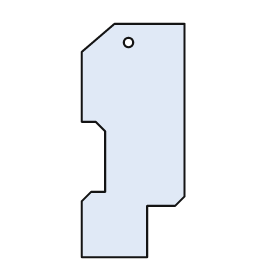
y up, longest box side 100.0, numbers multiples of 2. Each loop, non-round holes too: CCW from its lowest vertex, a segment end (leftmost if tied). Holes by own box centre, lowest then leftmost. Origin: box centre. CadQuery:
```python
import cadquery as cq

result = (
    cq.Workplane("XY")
    .moveTo(-22.0, -50.0)
    .lineTo(6.0, -50.0)
    .lineTo(6.0, -28.0)
    .lineTo(18.0, -28.0)
    .lineTo(22.0, -24.0)
    .lineTo(22.0, 50.0)
    .lineTo(-8.0, 50.0)
    .lineTo(-22.0, 38.0)
    .lineTo(-22.0, 8.0)
    .lineTo(-16.0, 8.0)
    .lineTo(-12.0, 4.0)
    .lineTo(-12.0, -22.0)
    .lineTo(-18.0, -22.0)
    .lineTo(-22.0, -26.0)
    .close()
    .moveTo(-2.0, 42.0)
    .circle(2.0)
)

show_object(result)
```